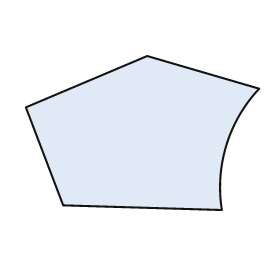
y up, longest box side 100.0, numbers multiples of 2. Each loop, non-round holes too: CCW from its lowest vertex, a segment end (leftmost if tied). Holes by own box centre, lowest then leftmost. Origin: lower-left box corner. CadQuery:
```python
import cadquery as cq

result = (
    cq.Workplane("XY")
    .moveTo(84.0, 0.0)
    .threePointArc((86.0, 28.0), (100.0, 52.0))
    .lineTo(52.0, 66.0)
    .lineTo(0.0, 44.0)
    .lineTo(16.0, 2.0)
    .close()
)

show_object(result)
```